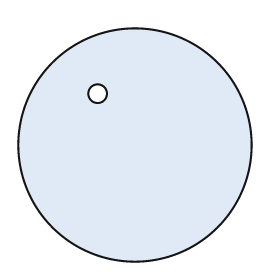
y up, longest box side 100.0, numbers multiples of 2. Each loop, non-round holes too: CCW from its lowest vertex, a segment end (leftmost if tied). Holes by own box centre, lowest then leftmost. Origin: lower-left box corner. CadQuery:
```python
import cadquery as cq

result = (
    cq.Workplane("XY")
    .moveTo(50.0, 50.0)
    .circle(50.0)
    .moveTo(34.0, 72.0)
    .circle(4.0)
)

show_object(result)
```